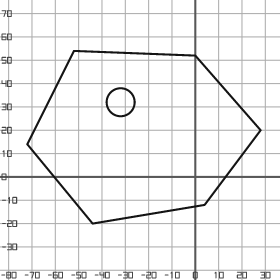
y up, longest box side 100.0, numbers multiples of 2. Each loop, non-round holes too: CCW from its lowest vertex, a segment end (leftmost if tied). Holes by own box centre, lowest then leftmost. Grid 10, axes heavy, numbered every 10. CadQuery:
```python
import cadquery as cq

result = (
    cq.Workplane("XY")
    .moveTo(-44.0, -20.0)
    .lineTo(4.0, -12.0)
    .lineTo(28.0, 20.0)
    .lineTo(0.0, 52.0)
    .lineTo(-52.0, 54.0)
    .lineTo(-72.0, 14.0)
    .close()
    .moveTo(-32.0, 32.0)
    .circle(6.0)
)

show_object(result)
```